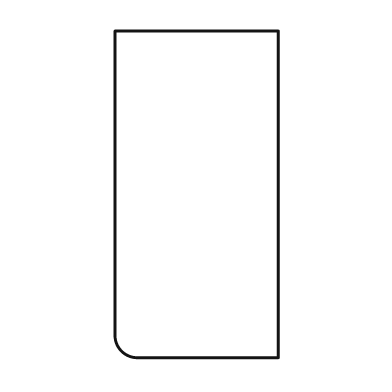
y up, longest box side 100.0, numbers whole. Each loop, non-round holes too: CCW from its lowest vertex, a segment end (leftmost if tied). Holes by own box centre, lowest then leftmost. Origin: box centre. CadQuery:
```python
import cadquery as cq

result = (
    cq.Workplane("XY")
    .moveTo(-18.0, -50.0)
    .lineTo(25.0, -50.0)
    .lineTo(25.0, 50.0)
    .lineTo(-25.0, 50.0)
    .lineTo(-25.0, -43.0)
    .threePointArc((-23.0, -48.0), (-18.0, -50.0))
    .close()
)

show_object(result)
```